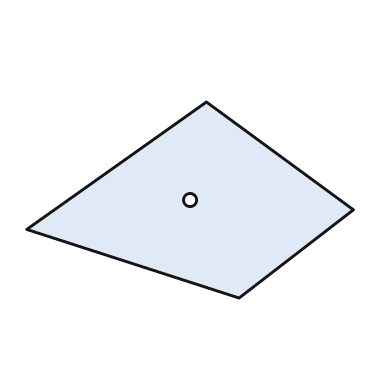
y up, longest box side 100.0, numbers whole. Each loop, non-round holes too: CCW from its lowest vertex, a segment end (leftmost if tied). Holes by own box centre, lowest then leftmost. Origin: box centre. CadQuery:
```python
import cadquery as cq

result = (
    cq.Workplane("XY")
    .moveTo(15.0, -30.0)
    .lineTo(50.0, -3.0)
    .lineTo(5.0, 30.0)
    .lineTo(-50.0, -9.0)
    .close()
    .moveTo(0.0, 0.0)
    .circle(2.0)
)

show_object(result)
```